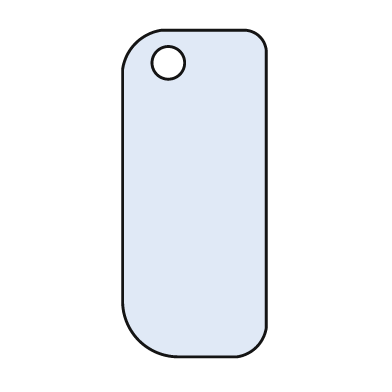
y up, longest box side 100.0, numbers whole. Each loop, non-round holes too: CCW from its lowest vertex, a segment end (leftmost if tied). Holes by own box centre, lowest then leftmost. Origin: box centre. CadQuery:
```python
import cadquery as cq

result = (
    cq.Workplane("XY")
    .moveTo(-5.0, -50.0)
    .lineTo(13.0, -50.0)
    .threePointArc((19.0, -47.0), (22.0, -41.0))
    .lineTo(22.0, 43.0)
    .threePointArc((20.0, 48.0), (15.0, 50.0))
    .lineTo(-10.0, 50.0)
    .threePointArc((-18.0, 46.0), (-22.0, 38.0))
    .lineTo(-22.0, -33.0)
    .threePointArc((-17.0, -45.0), (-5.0, -50.0))
    .close()
    .moveTo(-8.0, 40.0)
    .circle(5.0)
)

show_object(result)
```